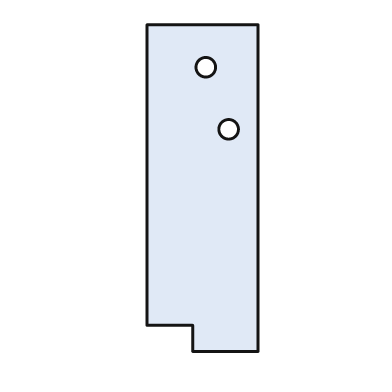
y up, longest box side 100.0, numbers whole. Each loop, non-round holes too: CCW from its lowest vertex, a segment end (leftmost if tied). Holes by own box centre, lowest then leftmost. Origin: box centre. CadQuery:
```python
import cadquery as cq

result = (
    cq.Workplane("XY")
    .moveTo(-3.0, -50.0)
    .lineTo(17.0, -50.0)
    .lineTo(17.0, 50.0)
    .lineTo(-17.0, 50.0)
    .lineTo(-17.0, -42.0)
    .lineTo(-3.0, -42.0)
    .close()
    .moveTo(8.0, 18.0)
    .circle(3.0)
    .moveTo(1.0, 37.0)
    .circle(3.0)
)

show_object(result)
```